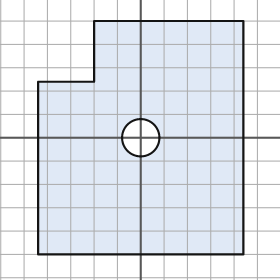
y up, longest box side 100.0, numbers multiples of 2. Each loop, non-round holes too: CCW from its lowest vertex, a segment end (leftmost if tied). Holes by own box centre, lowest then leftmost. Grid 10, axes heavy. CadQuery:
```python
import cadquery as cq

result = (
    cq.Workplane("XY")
    .moveTo(-44.0, -50.0)
    .lineTo(44.0, -50.0)
    .lineTo(44.0, 50.0)
    .lineTo(-20.0, 50.0)
    .lineTo(-20.0, 24.0)
    .lineTo(-44.0, 24.0)
    .close()
    .moveTo(0.0, 0.0)
    .circle(8.0)
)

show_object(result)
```